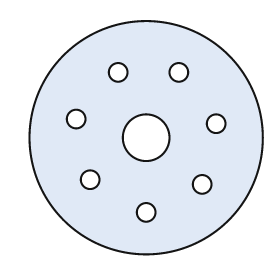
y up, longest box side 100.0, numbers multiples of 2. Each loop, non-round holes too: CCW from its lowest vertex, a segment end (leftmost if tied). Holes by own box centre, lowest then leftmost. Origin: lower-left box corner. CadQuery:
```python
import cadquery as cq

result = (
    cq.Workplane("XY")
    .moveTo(50.0, 50.0)
    .circle(50.0)
    .moveTo(50.0, 18.0)
    .circle(4.0)
    .moveTo(74.0, 30.0)
    .circle(4.0)
    .moveTo(26.0, 32.0)
    .circle(4.0)
    .moveTo(50.0, 50.0)
    .circle(10.0)
    .moveTo(80.0, 56.0)
    .circle(4.0)
    .moveTo(20.0, 58.0)
    .circle(4.0)
    .moveTo(38.0, 78.0)
    .circle(4.0)
    .moveTo(64.0, 78.0)
    .circle(4.0)
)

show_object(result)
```